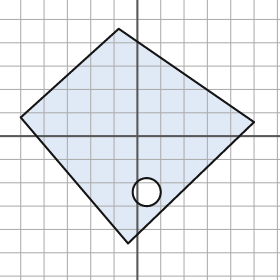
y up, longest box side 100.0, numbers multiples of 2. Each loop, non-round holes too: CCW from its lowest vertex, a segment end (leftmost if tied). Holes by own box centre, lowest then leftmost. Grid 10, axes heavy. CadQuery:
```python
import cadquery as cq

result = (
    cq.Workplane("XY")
    .moveTo(-4.0, -46.0)
    .lineTo(50.0, 6.0)
    .lineTo(-8.0, 46.0)
    .lineTo(-50.0, 8.0)
    .close()
    .moveTo(4.0, -24.0)
    .circle(6.0)
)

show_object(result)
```